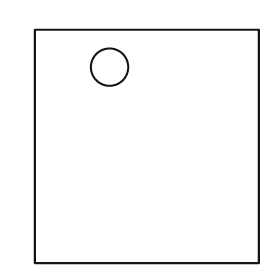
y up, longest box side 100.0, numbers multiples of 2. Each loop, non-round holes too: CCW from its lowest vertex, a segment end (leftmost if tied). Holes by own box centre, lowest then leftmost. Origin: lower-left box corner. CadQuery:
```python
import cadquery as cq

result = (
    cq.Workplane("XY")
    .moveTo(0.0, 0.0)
    .lineTo(96.0, 0.0)
    .lineTo(96.0, 100.0)
    .lineTo(0.0, 100.0)
    .close()
    .moveTo(32.0, 84.0)
    .circle(8.0)
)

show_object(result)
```